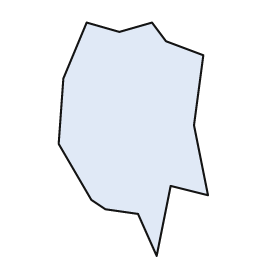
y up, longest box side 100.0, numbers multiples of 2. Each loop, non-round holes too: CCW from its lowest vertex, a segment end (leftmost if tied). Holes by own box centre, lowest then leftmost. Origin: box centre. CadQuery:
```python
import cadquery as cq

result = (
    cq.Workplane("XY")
    .moveTo(10.0, -50.0)
    .lineTo(16.0, -20.0)
    .lineTo(32.0, -24.0)
    .lineTo(26.0, 6.0)
    .lineTo(30.0, 36.0)
    .lineTo(14.0, 42.0)
    .lineTo(8.0, 50.0)
    .lineTo(-6.0, 46.0)
    .lineTo(-20.0, 50.0)
    .lineTo(-30.0, 26.0)
    .lineTo(-32.0, -2.0)
    .lineTo(-18.0, -26.0)
    .lineTo(-12.0, -30.0)
    .lineTo(2.0, -32.0)
    .close()
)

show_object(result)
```